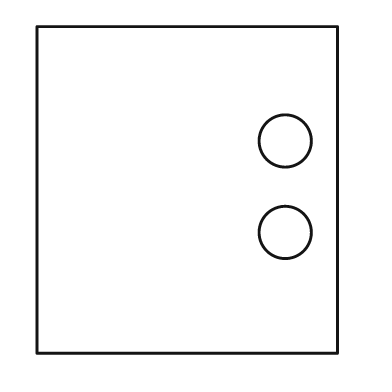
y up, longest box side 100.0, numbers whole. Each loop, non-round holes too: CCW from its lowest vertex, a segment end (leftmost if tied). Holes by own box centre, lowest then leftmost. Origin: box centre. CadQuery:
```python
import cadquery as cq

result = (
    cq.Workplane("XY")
    .moveTo(-46.0, -50.0)
    .lineTo(46.0, -50.0)
    .lineTo(46.0, 50.0)
    .lineTo(-46.0, 50.0)
    .close()
    .moveTo(30.0, -13.0)
    .circle(8.0)
    .moveTo(30.0, 15.0)
    .circle(8.0)
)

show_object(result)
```